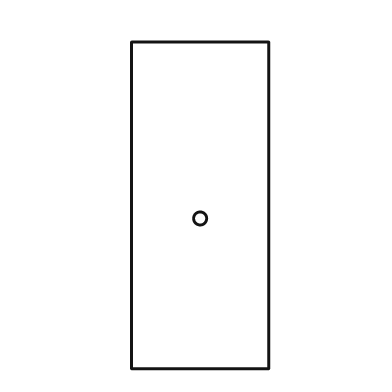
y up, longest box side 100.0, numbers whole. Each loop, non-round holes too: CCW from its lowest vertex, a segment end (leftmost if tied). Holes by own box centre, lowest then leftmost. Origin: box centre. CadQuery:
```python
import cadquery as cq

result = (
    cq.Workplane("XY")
    .moveTo(-21.0, -50.0)
    .lineTo(21.0, -50.0)
    .lineTo(21.0, 50.0)
    .lineTo(-21.0, 50.0)
    .close()
    .moveTo(0.0, -4.0)
    .circle(2.0)
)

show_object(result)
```